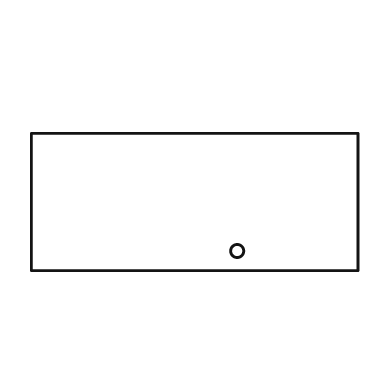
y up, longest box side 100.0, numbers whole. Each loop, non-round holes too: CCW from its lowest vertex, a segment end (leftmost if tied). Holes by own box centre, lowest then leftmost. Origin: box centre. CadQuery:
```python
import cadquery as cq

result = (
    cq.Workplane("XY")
    .moveTo(-50.0, -21.0)
    .lineTo(50.0, -21.0)
    .lineTo(50.0, 21.0)
    .lineTo(-50.0, 21.0)
    .close()
    .moveTo(13.0, -15.0)
    .circle(2.0)
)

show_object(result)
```